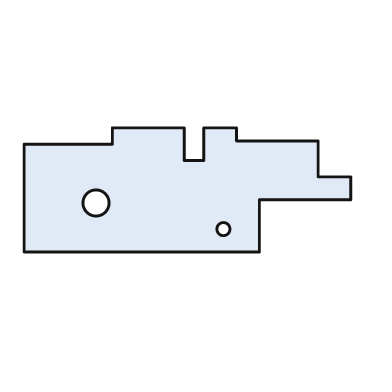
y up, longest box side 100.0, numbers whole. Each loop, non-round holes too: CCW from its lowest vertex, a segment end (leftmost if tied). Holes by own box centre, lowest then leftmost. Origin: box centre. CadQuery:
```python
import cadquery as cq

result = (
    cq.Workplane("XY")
    .moveTo(-50.0, -19.0)
    .lineTo(22.0, -19.0)
    .lineTo(22.0, -3.0)
    .lineTo(50.0, -3.0)
    .lineTo(50.0, 4.0)
    .lineTo(40.0, 4.0)
    .lineTo(40.0, 15.0)
    .lineTo(15.0, 15.0)
    .lineTo(15.0, 19.0)
    .lineTo(5.0, 19.0)
    .lineTo(5.0, 9.0)
    .lineTo(-1.0, 9.0)
    .lineTo(-1.0, 19.0)
    .lineTo(-23.0, 19.0)
    .lineTo(-23.0, 14.0)
    .lineTo(-50.0, 14.0)
    .close()
    .moveTo(11.0, -12.0)
    .circle(2.0)
    .moveTo(-28.0, -4.0)
    .circle(4.0)
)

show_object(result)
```